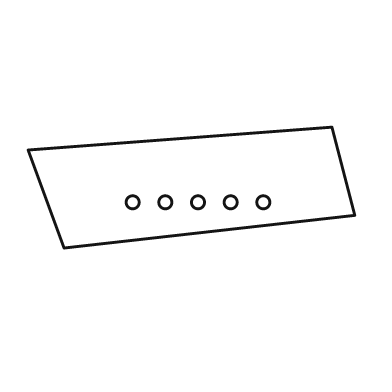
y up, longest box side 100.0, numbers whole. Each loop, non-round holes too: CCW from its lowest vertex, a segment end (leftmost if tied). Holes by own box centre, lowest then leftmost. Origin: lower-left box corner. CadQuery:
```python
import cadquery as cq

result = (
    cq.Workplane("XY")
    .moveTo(11.0, 0.0)
    .lineTo(100.0, 10.0)
    .lineTo(93.0, 37.0)
    .lineTo(0.0, 30.0)
    .close()
    .moveTo(32.0, 14.0)
    .circle(2.0)
    .moveTo(42.0, 14.0)
    .circle(2.0)
    .moveTo(52.0, 14.0)
    .circle(2.0)
    .moveTo(62.0, 14.0)
    .circle(2.0)
    .moveTo(72.0, 14.0)
    .circle(2.0)
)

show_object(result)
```